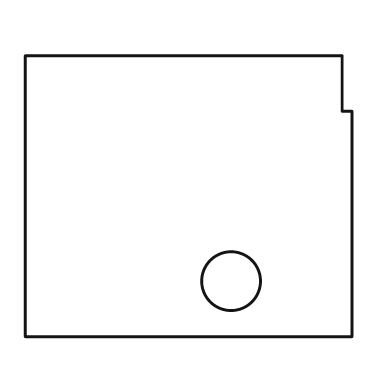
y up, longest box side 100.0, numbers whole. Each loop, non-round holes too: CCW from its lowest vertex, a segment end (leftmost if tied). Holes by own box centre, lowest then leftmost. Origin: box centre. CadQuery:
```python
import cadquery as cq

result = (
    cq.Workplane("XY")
    .moveTo(-50.0, -43.0)
    .lineTo(50.0, -43.0)
    .lineTo(50.0, 26.0)
    .lineTo(47.0, 26.0)
    .lineTo(47.0, 43.0)
    .lineTo(-50.0, 43.0)
    .close()
    .moveTo(13.0, -26.0)
    .circle(9.0)
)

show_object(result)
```